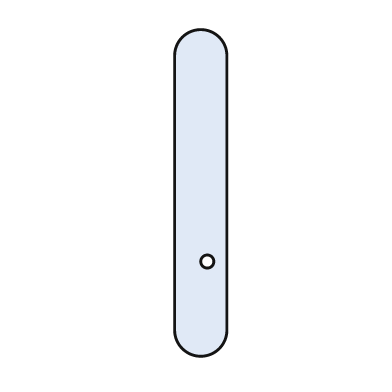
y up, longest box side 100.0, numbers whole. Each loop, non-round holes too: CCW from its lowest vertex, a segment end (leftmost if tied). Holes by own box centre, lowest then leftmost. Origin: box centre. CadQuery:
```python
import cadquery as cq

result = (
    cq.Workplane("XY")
    .moveTo(-8.0, -42.0)
    .threePointArc((0.0, -50.0), (8.0, -42.0))
    .lineTo(8.0, 42.0)
    .threePointArc((0.0, 50.0), (-8.0, 42.0))
    .close()
    .moveTo(2.0, -21.0)
    .circle(2.0)
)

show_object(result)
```